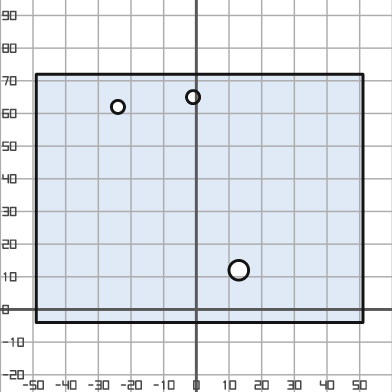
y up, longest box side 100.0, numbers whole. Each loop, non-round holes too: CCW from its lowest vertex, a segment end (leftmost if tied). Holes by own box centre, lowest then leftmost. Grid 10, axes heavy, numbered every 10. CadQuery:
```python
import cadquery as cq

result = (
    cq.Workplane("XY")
    .moveTo(-49.0, -4.0)
    .lineTo(51.0, -4.0)
    .lineTo(51.0, 72.0)
    .lineTo(-49.0, 72.0)
    .close()
    .moveTo(13.0, 12.0)
    .circle(3.0)
    .moveTo(-24.0, 62.0)
    .circle(2.0)
    .moveTo(-1.0, 65.0)
    .circle(2.0)
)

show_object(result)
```